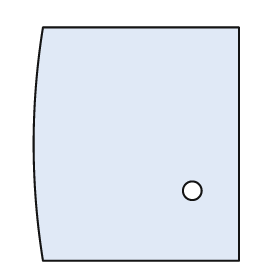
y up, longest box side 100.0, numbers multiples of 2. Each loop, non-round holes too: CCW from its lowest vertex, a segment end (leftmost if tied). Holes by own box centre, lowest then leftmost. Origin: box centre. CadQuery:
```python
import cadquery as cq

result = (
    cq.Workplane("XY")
    .moveTo(-40.0, -50.0)
    .lineTo(44.0, -50.0)
    .lineTo(44.0, 50.0)
    .lineTo(-40.0, 50.0)
    .threePointArc((-44.0, 0.0), (-40.0, -50.0))
    .close()
    .moveTo(24.0, -20.0)
    .circle(4.0)
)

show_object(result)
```